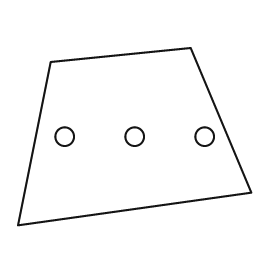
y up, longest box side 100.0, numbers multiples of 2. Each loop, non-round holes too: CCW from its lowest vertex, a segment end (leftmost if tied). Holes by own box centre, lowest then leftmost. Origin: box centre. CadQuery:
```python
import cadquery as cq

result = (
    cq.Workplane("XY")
    .moveTo(-50.0, -38.0)
    .lineTo(50.0, -24.0)
    .lineTo(24.0, 38.0)
    .lineTo(-36.0, 32.0)
    .close()
    .moveTo(-30.0, 0.0)
    .circle(4.0)
    .moveTo(0.0, 0.0)
    .circle(4.0)
    .moveTo(30.0, 0.0)
    .circle(4.0)
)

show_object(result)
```